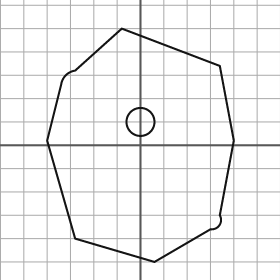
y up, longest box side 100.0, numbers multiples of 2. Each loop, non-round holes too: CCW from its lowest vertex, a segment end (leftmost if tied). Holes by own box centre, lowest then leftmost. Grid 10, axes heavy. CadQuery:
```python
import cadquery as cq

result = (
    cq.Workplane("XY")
    .moveTo(6.0, -50.0)
    .lineTo(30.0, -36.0)
    .threePointArc((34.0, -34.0), (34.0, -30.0))
    .lineTo(40.0, 2.0)
    .lineTo(34.0, 34.0)
    .lineTo(-8.0, 50.0)
    .lineTo(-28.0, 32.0)
    .threePointArc((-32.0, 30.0), (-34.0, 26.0))
    .lineTo(-40.0, 2.0)
    .lineTo(-28.0, -40.0)
    .close()
    .moveTo(0.0, 10.0)
    .circle(6.0)
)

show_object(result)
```